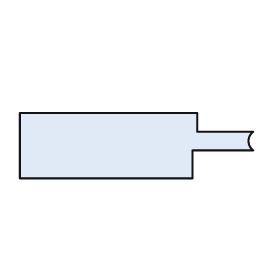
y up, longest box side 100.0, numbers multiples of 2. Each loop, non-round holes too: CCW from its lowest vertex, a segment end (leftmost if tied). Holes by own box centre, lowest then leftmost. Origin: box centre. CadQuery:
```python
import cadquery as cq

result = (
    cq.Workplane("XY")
    .moveTo(-50.0, -14.0)
    .lineTo(24.0, -14.0)
    .lineTo(24.0, -2.0)
    .lineTo(50.0, -2.0)
    .threePointArc((48.0, 2.0), (50.0, 6.0))
    .lineTo(26.0, 6.0)
    .lineTo(26.0, 14.0)
    .lineTo(-50.0, 14.0)
    .close()
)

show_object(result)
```